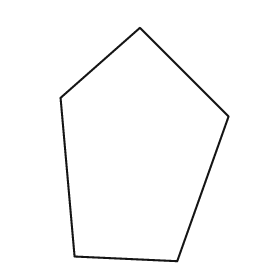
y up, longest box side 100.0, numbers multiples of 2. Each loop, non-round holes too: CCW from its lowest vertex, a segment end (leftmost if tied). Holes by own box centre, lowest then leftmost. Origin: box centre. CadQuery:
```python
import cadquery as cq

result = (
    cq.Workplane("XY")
    .moveTo(14.0, -50.0)
    .lineTo(36.0, 12.0)
    .lineTo(-2.0, 50.0)
    .lineTo(-36.0, 20.0)
    .lineTo(-30.0, -48.0)
    .close()
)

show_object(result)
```